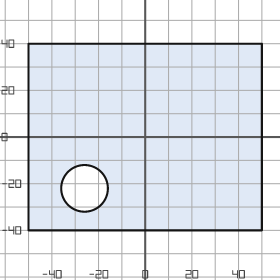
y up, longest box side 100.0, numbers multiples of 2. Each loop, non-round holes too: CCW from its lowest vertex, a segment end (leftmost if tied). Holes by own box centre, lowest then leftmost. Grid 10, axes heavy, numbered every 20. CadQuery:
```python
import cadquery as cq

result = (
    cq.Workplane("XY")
    .moveTo(-50.0, -40.0)
    .lineTo(50.0, -40.0)
    .lineTo(50.0, 40.0)
    .lineTo(-50.0, 40.0)
    .close()
    .moveTo(-26.0, -22.0)
    .circle(10.0)
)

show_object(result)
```